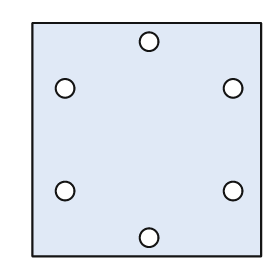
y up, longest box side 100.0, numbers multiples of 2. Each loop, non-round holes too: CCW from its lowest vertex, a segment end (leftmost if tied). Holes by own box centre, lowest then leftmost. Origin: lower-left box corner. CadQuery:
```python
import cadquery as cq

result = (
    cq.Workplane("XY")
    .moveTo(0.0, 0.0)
    .lineTo(98.0, 0.0)
    .lineTo(98.0, 100.0)
    .lineTo(0.0, 100.0)
    .close()
    .moveTo(50.0, 8.0)
    .circle(4.0)
    .moveTo(14.0, 28.0)
    .circle(4.0)
    .moveTo(86.0, 28.0)
    .circle(4.0)
    .moveTo(14.0, 72.0)
    .circle(4.0)
    .moveTo(86.0, 72.0)
    .circle(4.0)
    .moveTo(50.0, 92.0)
    .circle(4.0)
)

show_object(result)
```